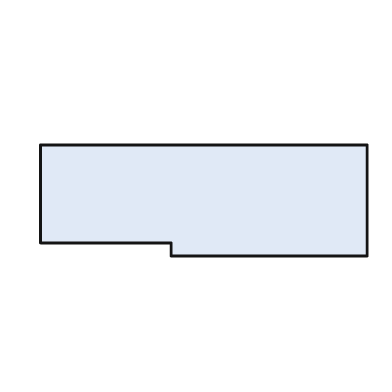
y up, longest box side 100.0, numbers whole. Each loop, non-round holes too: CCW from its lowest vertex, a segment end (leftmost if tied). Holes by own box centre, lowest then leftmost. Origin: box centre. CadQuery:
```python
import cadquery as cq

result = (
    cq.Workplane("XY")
    .moveTo(-10.0, -17.0)
    .lineTo(50.0, -17.0)
    .lineTo(50.0, 17.0)
    .lineTo(-50.0, 17.0)
    .lineTo(-50.0, -13.0)
    .lineTo(-10.0, -13.0)
    .close()
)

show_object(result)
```